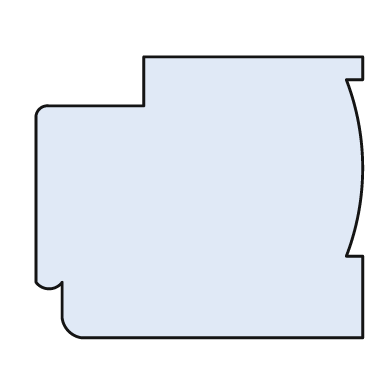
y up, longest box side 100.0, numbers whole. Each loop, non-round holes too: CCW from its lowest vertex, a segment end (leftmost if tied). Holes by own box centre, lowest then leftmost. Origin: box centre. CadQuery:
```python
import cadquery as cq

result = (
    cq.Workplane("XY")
    .moveTo(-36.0, -43.0)
    .lineTo(50.0, -43.0)
    .lineTo(50.0, -18.0)
    .lineTo(45.0, -18.0)
    .threePointArc((50.0, 9.0), (45.0, 36.0))
    .lineTo(50.0, 36.0)
    .lineTo(50.0, 43.0)
    .lineTo(-17.0, 43.0)
    .lineTo(-17.0, 28.0)
    .lineTo(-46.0, 28.0)
    .threePointArc((-49.0, 27.0), (-50.0, 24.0))
    .lineTo(-50.0, -26.0)
    .threePointArc((-46.0, -28.0), (-42.0, -26.0))
    .lineTo(-42.0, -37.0)
    .threePointArc((-40.0, -41.0), (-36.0, -43.0))
    .close()
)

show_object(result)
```